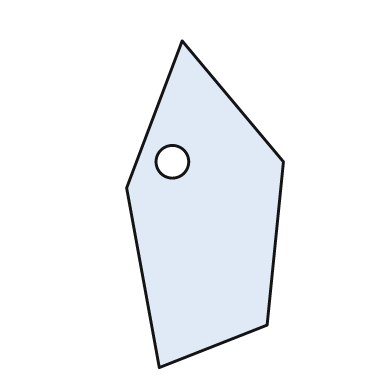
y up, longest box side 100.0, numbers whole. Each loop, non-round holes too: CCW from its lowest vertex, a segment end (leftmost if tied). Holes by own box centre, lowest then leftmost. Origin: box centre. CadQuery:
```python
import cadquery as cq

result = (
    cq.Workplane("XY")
    .moveTo(-14.0, -50.0)
    .lineTo(19.0, -37.0)
    .lineTo(24.0, 13.0)
    .lineTo(-7.0, 50.0)
    .lineTo(-24.0, 5.0)
    .close()
    .moveTo(-10.0, 13.0)
    .circle(5.0)
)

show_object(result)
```